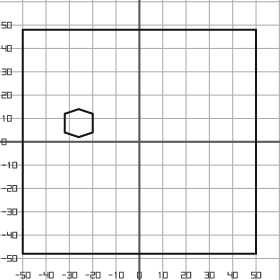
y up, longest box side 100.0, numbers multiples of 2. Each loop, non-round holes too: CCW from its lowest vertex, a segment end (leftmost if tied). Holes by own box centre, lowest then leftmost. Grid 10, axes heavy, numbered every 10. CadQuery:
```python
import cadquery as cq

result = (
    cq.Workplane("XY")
    .moveTo(-50.0, -48.0)
    .lineTo(50.0, -48.0)
    .lineTo(50.0, 48.0)
    .lineTo(-50.0, 48.0)
    .close()
    .moveTo(-26.0, 2.0)
    .lineTo(-20.0, 4.0)
    .lineTo(-20.0, 12.0)
    .lineTo(-26.0, 14.0)
    .lineTo(-32.0, 12.0)
    .lineTo(-32.0, 4.0)
    .close()
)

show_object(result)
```